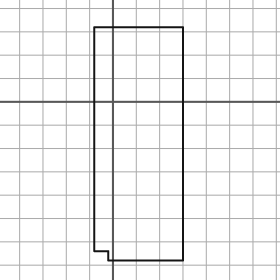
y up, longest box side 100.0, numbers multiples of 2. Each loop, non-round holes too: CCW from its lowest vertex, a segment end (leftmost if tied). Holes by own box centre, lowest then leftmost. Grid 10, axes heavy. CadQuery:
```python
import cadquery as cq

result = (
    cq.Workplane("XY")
    .moveTo(-2.0, -68.0)
    .lineTo(30.0, -68.0)
    .lineTo(30.0, 32.0)
    .lineTo(-8.0, 32.0)
    .lineTo(-8.0, -64.0)
    .lineTo(-2.0, -64.0)
    .close()
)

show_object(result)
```